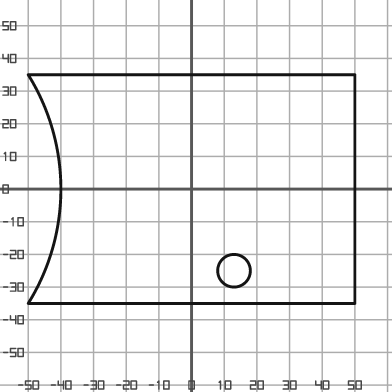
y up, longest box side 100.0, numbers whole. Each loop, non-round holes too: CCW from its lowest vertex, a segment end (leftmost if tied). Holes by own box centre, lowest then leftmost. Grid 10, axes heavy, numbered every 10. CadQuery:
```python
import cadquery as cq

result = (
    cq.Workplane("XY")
    .moveTo(-50.0, -35.0)
    .lineTo(50.0, -35.0)
    .lineTo(50.0, 35.0)
    .lineTo(-50.0, 35.0)
    .threePointArc((-40.0, 0.0), (-50.0, -35.0))
    .close()
    .moveTo(13.0, -25.0)
    .circle(5.0)
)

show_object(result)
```